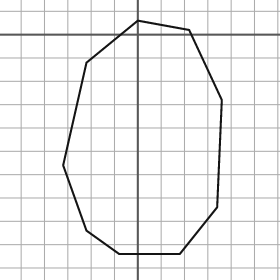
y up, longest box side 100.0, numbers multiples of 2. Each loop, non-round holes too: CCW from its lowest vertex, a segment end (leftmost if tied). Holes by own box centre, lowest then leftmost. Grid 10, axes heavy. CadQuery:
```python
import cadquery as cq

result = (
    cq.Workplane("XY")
    .moveTo(-8.0, -94.0)
    .lineTo(18.0, -94.0)
    .lineTo(34.0, -74.0)
    .lineTo(36.0, -28.0)
    .lineTo(22.0, 2.0)
    .lineTo(0.0, 6.0)
    .lineTo(-22.0, -12.0)
    .lineTo(-32.0, -56.0)
    .lineTo(-22.0, -84.0)
    .close()
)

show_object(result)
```